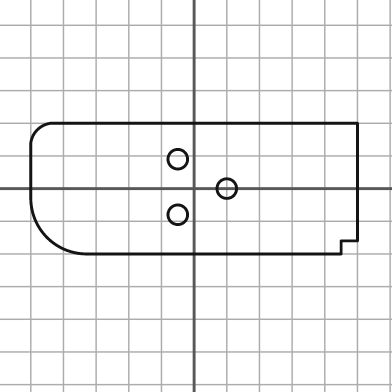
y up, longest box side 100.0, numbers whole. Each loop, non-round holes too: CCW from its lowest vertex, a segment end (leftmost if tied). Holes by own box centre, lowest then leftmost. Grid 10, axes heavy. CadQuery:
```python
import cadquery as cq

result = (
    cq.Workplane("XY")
    .moveTo(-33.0, -20.0)
    .lineTo(45.0, -20.0)
    .lineTo(45.0, -16.0)
    .lineTo(50.0, -16.0)
    .lineTo(50.0, 20.0)
    .lineTo(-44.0, 20.0)
    .threePointArc((-48.0, 18.0), (-50.0, 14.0))
    .lineTo(-50.0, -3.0)
    .threePointArc((-45.0, -15.0), (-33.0, -20.0))
    .close()
    .moveTo(-5.0, -8.0)
    .circle(3.0)
    .moveTo(10.0, 0.0)
    .circle(3.0)
    .moveTo(-5.0, 9.0)
    .circle(3.0)
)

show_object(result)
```